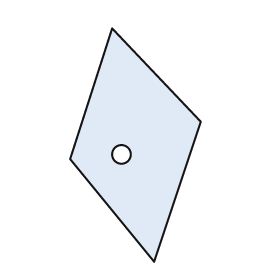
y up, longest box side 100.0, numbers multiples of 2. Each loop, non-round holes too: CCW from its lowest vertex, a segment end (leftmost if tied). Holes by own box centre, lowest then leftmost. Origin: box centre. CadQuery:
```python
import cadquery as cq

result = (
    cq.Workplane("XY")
    .moveTo(8.0, -50.0)
    .lineTo(28.0, 10.0)
    .lineTo(-10.0, 50.0)
    .lineTo(-28.0, -6.0)
    .close()
    .moveTo(-6.0, -4.0)
    .circle(4.0)
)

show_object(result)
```